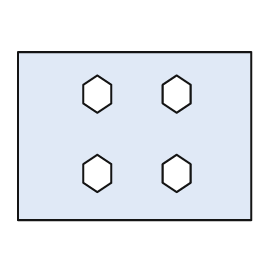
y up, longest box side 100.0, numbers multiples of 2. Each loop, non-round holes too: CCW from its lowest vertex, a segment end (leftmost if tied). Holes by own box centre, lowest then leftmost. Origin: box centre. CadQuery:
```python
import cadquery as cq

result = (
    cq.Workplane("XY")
    .moveTo(-50.0, -36.0)
    .lineTo(50.0, -36.0)
    .lineTo(50.0, 36.0)
    .lineTo(-50.0, 36.0)
    .close()
    .moveTo(-16.0, -24.0)
    .lineTo(-10.0, -20.0)
    .lineTo(-10.0, -12.0)
    .lineTo(-16.0, -8.0)
    .lineTo(-22.0, -12.0)
    .lineTo(-22.0, -20.0)
    .close()
    .moveTo(18.0, -24.0)
    .lineTo(24.0, -20.0)
    .lineTo(24.0, -12.0)
    .lineTo(18.0, -8.0)
    .lineTo(12.0, -12.0)
    .lineTo(12.0, -20.0)
    .close()
    .moveTo(-16.0, 10.0)
    .lineTo(-10.0, 14.0)
    .lineTo(-10.0, 22.0)
    .lineTo(-16.0, 26.0)
    .lineTo(-22.0, 22.0)
    .lineTo(-22.0, 14.0)
    .close()
    .moveTo(18.0, 10.0)
    .lineTo(24.0, 14.0)
    .lineTo(24.0, 22.0)
    .lineTo(18.0, 26.0)
    .lineTo(12.0, 22.0)
    .lineTo(12.0, 14.0)
    .close()
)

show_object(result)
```